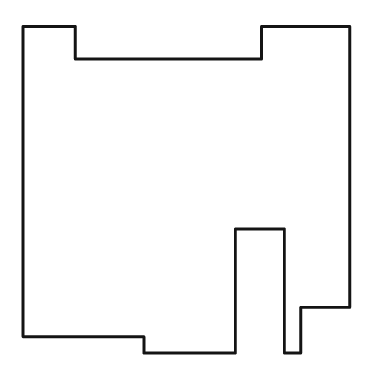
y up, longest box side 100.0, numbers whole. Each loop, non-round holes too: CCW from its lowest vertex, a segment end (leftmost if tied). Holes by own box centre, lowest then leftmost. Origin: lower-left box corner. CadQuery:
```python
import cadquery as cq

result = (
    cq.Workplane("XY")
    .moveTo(37.0, 0.0)
    .lineTo(65.0, 0.0)
    .lineTo(65.0, 38.0)
    .lineTo(80.0, 38.0)
    .lineTo(80.0, 0.0)
    .lineTo(85.0, 0.0)
    .lineTo(85.0, 14.0)
    .lineTo(100.0, 14.0)
    .lineTo(100.0, 100.0)
    .lineTo(73.0, 100.0)
    .lineTo(73.0, 90.0)
    .lineTo(16.0, 90.0)
    .lineTo(16.0, 100.0)
    .lineTo(0.0, 100.0)
    .lineTo(0.0, 5.0)
    .lineTo(37.0, 5.0)
    .close()
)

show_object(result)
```